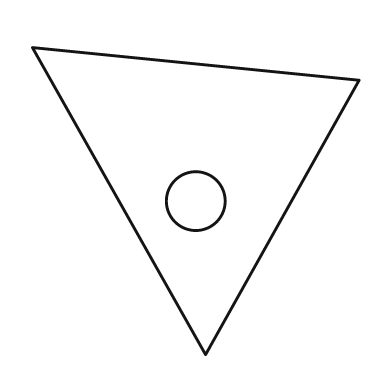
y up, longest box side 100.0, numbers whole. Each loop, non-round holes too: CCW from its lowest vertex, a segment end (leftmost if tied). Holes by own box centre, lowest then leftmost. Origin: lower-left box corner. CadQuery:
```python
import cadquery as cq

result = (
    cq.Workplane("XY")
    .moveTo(53.0, 0.0)
    .lineTo(100.0, 84.0)
    .lineTo(0.0, 94.0)
    .close()
    .moveTo(50.0, 47.0)
    .circle(9.0)
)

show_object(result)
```